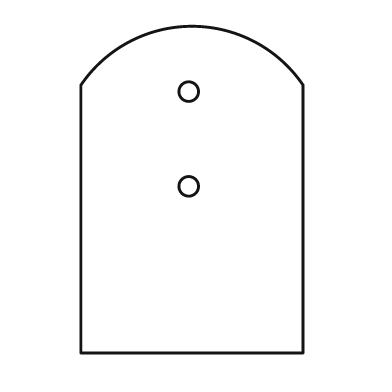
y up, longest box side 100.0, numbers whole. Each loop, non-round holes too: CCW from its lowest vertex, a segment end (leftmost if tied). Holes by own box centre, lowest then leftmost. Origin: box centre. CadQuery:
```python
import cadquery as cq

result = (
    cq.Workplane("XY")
    .moveTo(-34.0, -50.0)
    .lineTo(34.0, -50.0)
    .lineTo(34.0, 32.0)
    .threePointArc((0.0, 50.0), (-34.0, 32.0))
    .close()
    .moveTo(-1.0, 1.0)
    .circle(3.0)
    .moveTo(-1.0, 30.0)
    .circle(3.0)
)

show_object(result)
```